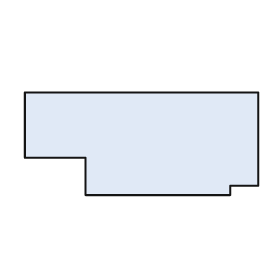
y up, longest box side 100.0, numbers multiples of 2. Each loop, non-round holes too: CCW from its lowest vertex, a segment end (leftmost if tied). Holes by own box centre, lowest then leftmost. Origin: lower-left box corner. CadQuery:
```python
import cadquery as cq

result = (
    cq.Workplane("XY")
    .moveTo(26.0, 0.0)
    .lineTo(88.0, 0.0)
    .lineTo(88.0, 4.0)
    .lineTo(100.0, 4.0)
    .lineTo(100.0, 44.0)
    .lineTo(0.0, 44.0)
    .lineTo(0.0, 16.0)
    .lineTo(26.0, 16.0)
    .close()
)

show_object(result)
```